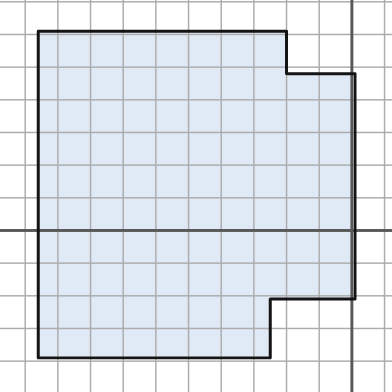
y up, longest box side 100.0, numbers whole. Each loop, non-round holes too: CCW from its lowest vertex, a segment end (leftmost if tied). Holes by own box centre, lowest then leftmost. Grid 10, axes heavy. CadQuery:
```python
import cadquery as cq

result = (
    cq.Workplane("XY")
    .moveTo(-96.0, -39.0)
    .lineTo(-25.0, -39.0)
    .lineTo(-25.0, -21.0)
    .lineTo(1.0, -21.0)
    .lineTo(1.0, 48.0)
    .lineTo(-20.0, 48.0)
    .lineTo(-20.0, 61.0)
    .lineTo(-96.0, 61.0)
    .close()
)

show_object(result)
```